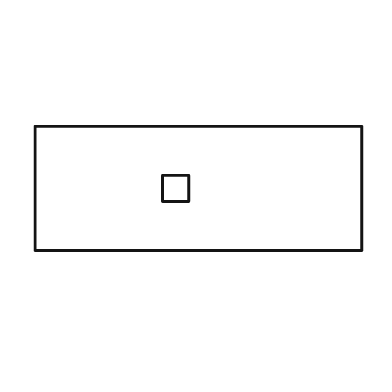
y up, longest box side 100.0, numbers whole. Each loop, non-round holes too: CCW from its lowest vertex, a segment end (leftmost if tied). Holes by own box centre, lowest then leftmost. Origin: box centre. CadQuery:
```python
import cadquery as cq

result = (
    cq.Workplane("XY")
    .moveTo(-50.0, -19.0)
    .lineTo(50.0, -19.0)
    .lineTo(50.0, 19.0)
    .lineTo(-50.0, 19.0)
    .close()
    .moveTo(-11.0, -4.0)
    .lineTo(-3.0, -4.0)
    .lineTo(-3.0, 4.0)
    .lineTo(-11.0, 4.0)
    .close()
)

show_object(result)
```